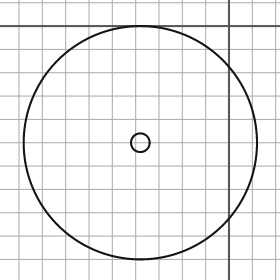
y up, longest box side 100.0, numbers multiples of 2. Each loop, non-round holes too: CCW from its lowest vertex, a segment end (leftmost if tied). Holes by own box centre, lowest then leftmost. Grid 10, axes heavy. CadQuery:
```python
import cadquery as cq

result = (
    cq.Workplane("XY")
    .moveTo(-38.0, -50.0)
    .circle(50.0)
    .moveTo(-38.0, -50.0)
    .circle(4.0)
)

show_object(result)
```